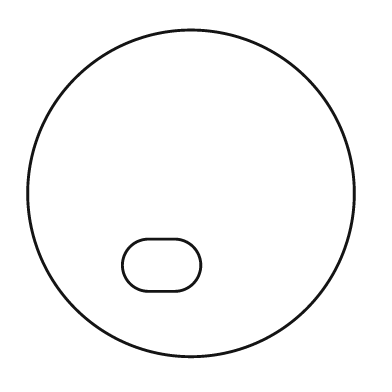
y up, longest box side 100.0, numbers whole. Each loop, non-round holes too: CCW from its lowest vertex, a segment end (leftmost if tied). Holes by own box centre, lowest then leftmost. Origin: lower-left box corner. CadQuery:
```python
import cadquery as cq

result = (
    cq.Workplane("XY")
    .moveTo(50.0, 50.0)
    .circle(50.0)
    .moveTo(37.0, 20.0)
    .lineTo(45.0, 20.0)
    .threePointArc((53.0, 28.0), (45.0, 36.0))
    .lineTo(37.0, 36.0)
    .threePointArc((29.0, 28.0), (37.0, 20.0))
    .close()
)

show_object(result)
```